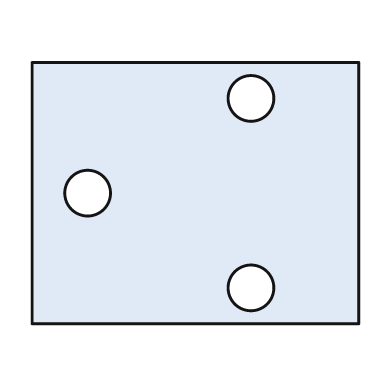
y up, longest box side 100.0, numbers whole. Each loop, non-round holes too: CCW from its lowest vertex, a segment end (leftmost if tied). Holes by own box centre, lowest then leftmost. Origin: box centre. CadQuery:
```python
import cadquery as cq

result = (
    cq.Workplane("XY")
    .moveTo(-50.0, -40.0)
    .lineTo(50.0, -40.0)
    .lineTo(50.0, 40.0)
    .lineTo(-50.0, 40.0)
    .close()
    .moveTo(17.0, -29.0)
    .circle(7.0)
    .moveTo(-33.0, 0.0)
    .circle(7.0)
    .moveTo(17.0, 29.0)
    .circle(7.0)
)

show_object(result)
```